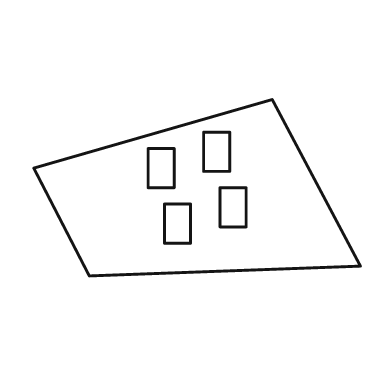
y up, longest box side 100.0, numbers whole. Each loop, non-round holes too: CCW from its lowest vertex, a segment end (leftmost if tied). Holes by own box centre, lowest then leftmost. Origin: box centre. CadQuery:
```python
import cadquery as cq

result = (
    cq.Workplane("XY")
    .moveTo(-33.0, -27.0)
    .lineTo(50.0, -24.0)
    .lineTo(23.0, 27.0)
    .lineTo(-50.0, 6.0)
    .close()
    .moveTo(-10.0, -17.0)
    .lineTo(-2.0, -17.0)
    .lineTo(-2.0, -5.0)
    .lineTo(-10.0, -5.0)
    .close()
    .moveTo(7.0, -12.0)
    .lineTo(15.0, -12.0)
    .lineTo(15.0, 0.0)
    .lineTo(7.0, 0.0)
    .close()
    .moveTo(-15.0, 0.0)
    .lineTo(-7.0, 0.0)
    .lineTo(-7.0, 12.0)
    .lineTo(-15.0, 12.0)
    .close()
    .moveTo(2.0, 5.0)
    .lineTo(10.0, 5.0)
    .lineTo(10.0, 17.0)
    .lineTo(2.0, 17.0)
    .close()
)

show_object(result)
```